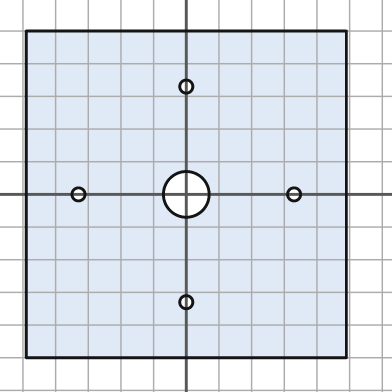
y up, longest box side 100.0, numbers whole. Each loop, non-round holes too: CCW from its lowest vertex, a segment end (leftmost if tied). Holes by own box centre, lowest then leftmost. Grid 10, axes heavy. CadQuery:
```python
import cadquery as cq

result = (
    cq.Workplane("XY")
    .moveTo(-49.0, -50.0)
    .lineTo(49.0, -50.0)
    .lineTo(49.0, 50.0)
    .lineTo(-49.0, 50.0)
    .close()
    .moveTo(0.0, -33.0)
    .circle(2.0)
    .moveTo(-33.0, 0.0)
    .circle(2.0)
    .moveTo(0.0, 0.0)
    .circle(7.0)
    .moveTo(33.0, 0.0)
    .circle(2.0)
    .moveTo(0.0, 33.0)
    .circle(2.0)
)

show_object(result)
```